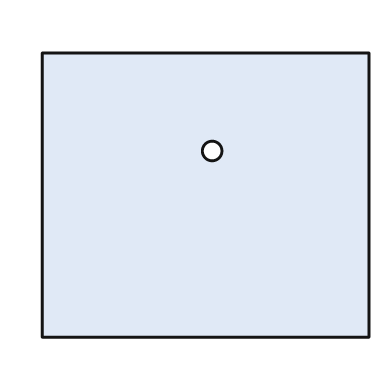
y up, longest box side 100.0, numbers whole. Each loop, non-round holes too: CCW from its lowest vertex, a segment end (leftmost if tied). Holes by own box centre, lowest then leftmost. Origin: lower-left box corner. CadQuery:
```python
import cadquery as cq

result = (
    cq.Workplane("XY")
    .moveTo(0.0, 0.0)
    .lineTo(100.0, 0.0)
    .lineTo(100.0, 87.0)
    .lineTo(0.0, 87.0)
    .close()
    .moveTo(52.0, 57.0)
    .circle(3.0)
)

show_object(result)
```